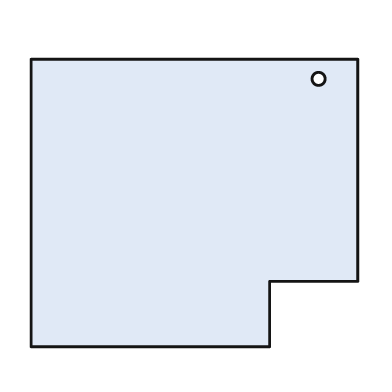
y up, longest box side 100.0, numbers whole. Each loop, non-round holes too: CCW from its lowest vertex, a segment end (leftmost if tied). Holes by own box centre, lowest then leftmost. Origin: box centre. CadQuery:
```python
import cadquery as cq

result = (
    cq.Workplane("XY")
    .moveTo(-50.0, -44.0)
    .lineTo(23.0, -44.0)
    .lineTo(23.0, -24.0)
    .lineTo(50.0, -24.0)
    .lineTo(50.0, 44.0)
    .lineTo(-50.0, 44.0)
    .close()
    .moveTo(38.0, 38.0)
    .circle(2.0)
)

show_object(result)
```